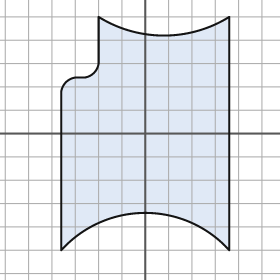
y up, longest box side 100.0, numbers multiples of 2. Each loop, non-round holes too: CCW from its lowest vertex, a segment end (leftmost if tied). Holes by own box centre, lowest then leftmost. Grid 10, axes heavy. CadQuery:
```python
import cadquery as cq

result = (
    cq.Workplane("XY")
    .moveTo(-36.0, -50.0)
    .threePointArc((0.0, -34.0), (36.0, -50.0))
    .lineTo(36.0, 50.0)
    .threePointArc((8.0, 42.0), (-20.0, 50.0))
    .lineTo(-20.0, 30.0)
    .threePointArc((-22.0, 26.0), (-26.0, 24.0))
    .lineTo(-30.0, 24.0)
    .threePointArc((-34.0, 22.0), (-36.0, 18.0))
    .close()
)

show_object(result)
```